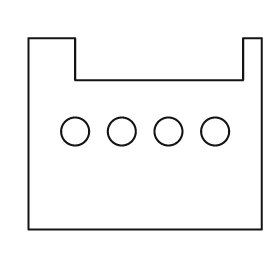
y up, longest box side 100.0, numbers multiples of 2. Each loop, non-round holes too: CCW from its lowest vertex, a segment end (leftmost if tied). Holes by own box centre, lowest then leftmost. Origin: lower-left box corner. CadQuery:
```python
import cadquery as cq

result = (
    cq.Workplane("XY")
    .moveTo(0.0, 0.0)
    .lineTo(100.0, 0.0)
    .lineTo(100.0, 82.0)
    .lineTo(92.0, 82.0)
    .lineTo(92.0, 64.0)
    .lineTo(20.0, 64.0)
    .lineTo(20.0, 82.0)
    .lineTo(0.0, 82.0)
    .close()
    .moveTo(20.0, 42.0)
    .circle(6.0)
    .moveTo(40.0, 42.0)
    .circle(6.0)
    .moveTo(60.0, 42.0)
    .circle(6.0)
    .moveTo(80.0, 42.0)
    .circle(6.0)
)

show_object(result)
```